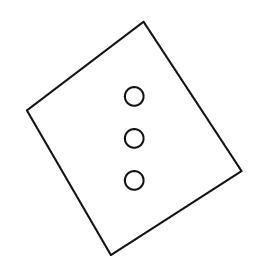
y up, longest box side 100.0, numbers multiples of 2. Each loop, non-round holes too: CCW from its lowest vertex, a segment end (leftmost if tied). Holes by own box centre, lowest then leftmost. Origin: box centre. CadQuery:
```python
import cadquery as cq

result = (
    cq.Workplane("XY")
    .moveTo(-10.0, -50.0)
    .lineTo(46.0, -14.0)
    .lineTo(4.0, 50.0)
    .lineTo(-46.0, 12.0)
    .close()
    .moveTo(0.0, -18.0)
    .circle(4.0)
    .moveTo(0.0, 0.0)
    .circle(4.0)
    .moveTo(0.0, 18.0)
    .circle(4.0)
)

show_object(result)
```